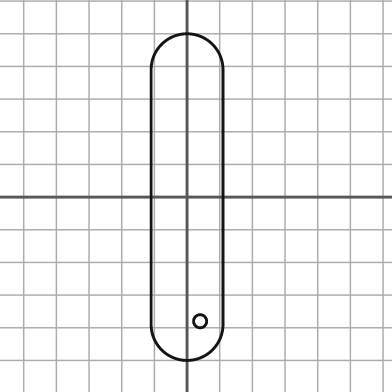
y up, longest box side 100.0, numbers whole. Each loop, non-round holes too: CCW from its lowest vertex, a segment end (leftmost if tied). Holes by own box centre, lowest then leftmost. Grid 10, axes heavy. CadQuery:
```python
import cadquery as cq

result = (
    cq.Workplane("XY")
    .moveTo(-11.0, -39.0)
    .threePointArc((0.0, -50.0), (11.0, -39.0))
    .lineTo(11.0, 39.0)
    .threePointArc((0.0, 50.0), (-11.0, 39.0))
    .close()
    .moveTo(4.0, -38.0)
    .circle(2.0)
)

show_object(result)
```